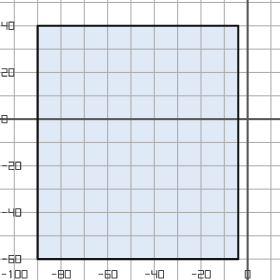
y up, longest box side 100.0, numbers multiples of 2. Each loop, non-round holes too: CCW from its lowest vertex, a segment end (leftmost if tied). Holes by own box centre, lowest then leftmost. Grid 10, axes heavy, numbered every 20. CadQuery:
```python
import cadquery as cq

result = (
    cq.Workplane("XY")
    .moveTo(-90.0, -60.0)
    .lineTo(-4.0, -60.0)
    .lineTo(-4.0, 40.0)
    .lineTo(-90.0, 40.0)
    .close()
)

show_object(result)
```